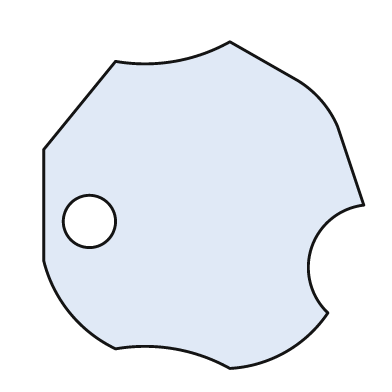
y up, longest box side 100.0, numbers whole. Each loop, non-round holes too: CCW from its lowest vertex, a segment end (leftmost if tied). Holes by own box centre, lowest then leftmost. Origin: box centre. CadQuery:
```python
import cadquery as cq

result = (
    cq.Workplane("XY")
    .moveTo(8.0, -50.0)
    .threePointArc((25.0, -45.0), (38.0, -33.0))
    .threePointArc((33.0, -13.0), (49.0, 0.0))
    .lineTo(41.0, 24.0)
    .threePointArc((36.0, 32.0), (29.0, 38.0))
    .lineTo(8.0, 50.0)
    .threePointArc((-9.0, 44.0), (-27.0, 44.0))
    .lineTo(-49.0, 17.0)
    .lineTo(-49.0, -17.0)
    .threePointArc((-41.0, -33.0), (-27.0, -44.0))
    .threePointArc((-9.0, -44.0), (8.0, -50.0))
    .close()
    .moveTo(-35.0, -5.0)
    .circle(8.0)
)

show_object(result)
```